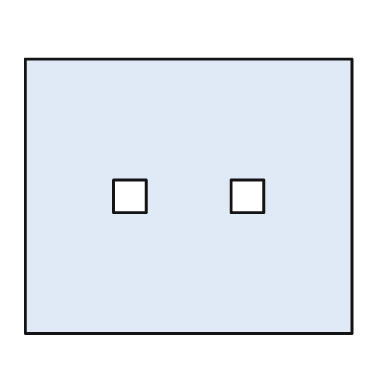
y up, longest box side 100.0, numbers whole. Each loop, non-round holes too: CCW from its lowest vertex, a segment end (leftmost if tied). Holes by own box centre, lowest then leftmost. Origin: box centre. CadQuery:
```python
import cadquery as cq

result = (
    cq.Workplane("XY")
    .moveTo(-50.0, -42.0)
    .lineTo(50.0, -42.0)
    .lineTo(50.0, 42.0)
    .lineTo(-50.0, 42.0)
    .close()
    .moveTo(-23.0, -5.0)
    .lineTo(-13.0, -5.0)
    .lineTo(-13.0, 5.0)
    .lineTo(-23.0, 5.0)
    .close()
    .moveTo(13.0, -5.0)
    .lineTo(23.0, -5.0)
    .lineTo(23.0, 5.0)
    .lineTo(13.0, 5.0)
    .close()
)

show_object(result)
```